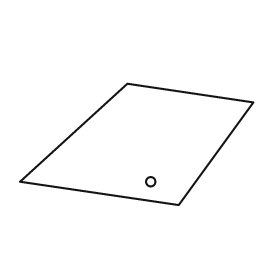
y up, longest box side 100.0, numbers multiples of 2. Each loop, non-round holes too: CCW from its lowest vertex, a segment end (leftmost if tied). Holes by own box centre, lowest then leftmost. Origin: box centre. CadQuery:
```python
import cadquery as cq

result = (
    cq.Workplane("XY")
    .moveTo(18.0, -26.0)
    .lineTo(50.0, 18.0)
    .lineTo(-4.0, 26.0)
    .lineTo(-50.0, -16.0)
    .close()
    .moveTo(6.0, -16.0)
    .circle(2.0)
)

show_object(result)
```